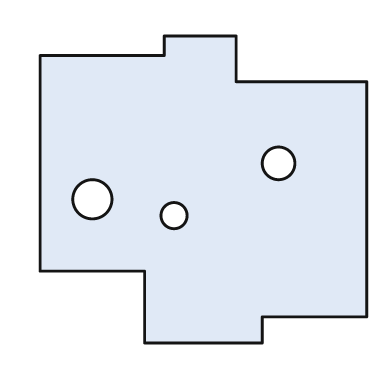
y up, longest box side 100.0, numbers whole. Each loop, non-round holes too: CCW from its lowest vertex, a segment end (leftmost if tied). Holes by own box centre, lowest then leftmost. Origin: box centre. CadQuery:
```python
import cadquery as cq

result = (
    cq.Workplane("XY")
    .moveTo(-18.0, -47.0)
    .lineTo(18.0, -47.0)
    .lineTo(18.0, -39.0)
    .lineTo(50.0, -39.0)
    .lineTo(50.0, 33.0)
    .lineTo(10.0, 33.0)
    .lineTo(10.0, 47.0)
    .lineTo(-12.0, 47.0)
    .lineTo(-12.0, 41.0)
    .lineTo(-50.0, 41.0)
    .lineTo(-50.0, -25.0)
    .lineTo(-18.0, -25.0)
    .close()
    .moveTo(-9.0, -8.0)
    .circle(4.0)
    .moveTo(-34.0, -3.0)
    .circle(6.0)
    .moveTo(23.0, 8.0)
    .circle(5.0)
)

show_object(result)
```